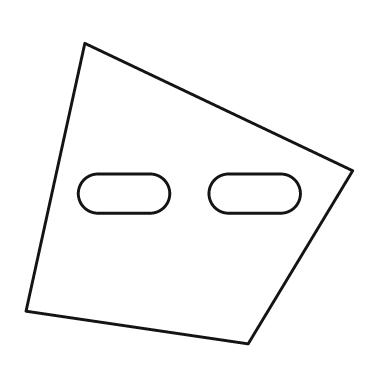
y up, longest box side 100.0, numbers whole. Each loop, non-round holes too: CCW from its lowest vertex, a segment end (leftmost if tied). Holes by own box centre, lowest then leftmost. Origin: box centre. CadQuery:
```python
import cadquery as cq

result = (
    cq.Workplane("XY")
    .moveTo(18.0, -46.0)
    .lineTo(50.0, 7.0)
    .lineTo(-32.0, 46.0)
    .lineTo(-50.0, -36.0)
    .close()
    .moveTo(-28.0, -6.0)
    .lineTo(-12.0, -6.0)
    .threePointArc((-6.0, 0.0), (-12.0, 6.0))
    .lineTo(-28.0, 6.0)
    .threePointArc((-34.0, 0.0), (-28.0, -6.0))
    .close()
    .moveTo(12.0, -6.0)
    .lineTo(28.0, -6.0)
    .threePointArc((34.0, 0.0), (28.0, 6.0))
    .lineTo(12.0, 6.0)
    .threePointArc((6.0, 0.0), (12.0, -6.0))
    .close()
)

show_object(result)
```